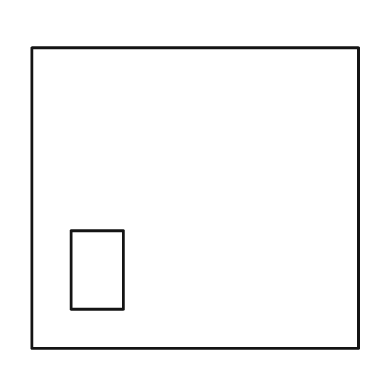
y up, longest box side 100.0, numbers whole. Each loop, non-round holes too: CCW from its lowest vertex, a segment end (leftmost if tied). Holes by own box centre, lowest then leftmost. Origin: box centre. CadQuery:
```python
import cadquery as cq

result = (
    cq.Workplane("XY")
    .moveTo(-50.0, -46.0)
    .lineTo(50.0, -46.0)
    .lineTo(50.0, 46.0)
    .lineTo(-50.0, 46.0)
    .close()
    .moveTo(-38.0, -34.0)
    .lineTo(-22.0, -34.0)
    .lineTo(-22.0, -10.0)
    .lineTo(-38.0, -10.0)
    .close()
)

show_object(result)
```